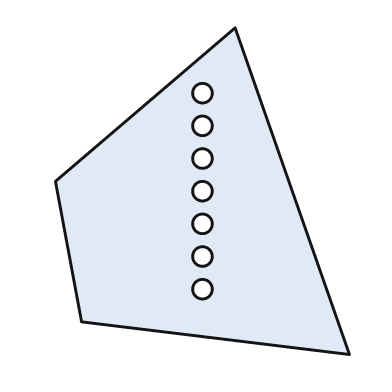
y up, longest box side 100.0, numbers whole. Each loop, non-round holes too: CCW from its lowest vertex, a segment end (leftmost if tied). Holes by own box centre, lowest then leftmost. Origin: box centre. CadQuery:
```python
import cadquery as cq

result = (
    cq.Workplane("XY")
    .moveTo(45.0, -50.0)
    .lineTo(10.0, 50.0)
    .lineTo(-45.0, 3.0)
    .lineTo(-37.0, -40.0)
    .close()
    .moveTo(0.0, -30.0)
    .circle(3.0)
    .moveTo(0.0, -20.0)
    .circle(3.0)
    .moveTo(0.0, -10.0)
    .circle(3.0)
    .moveTo(0.0, 0.0)
    .circle(3.0)
    .moveTo(0.0, 10.0)
    .circle(3.0)
    .moveTo(0.0, 20.0)
    .circle(3.0)
    .moveTo(0.0, 30.0)
    .circle(3.0)
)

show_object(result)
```